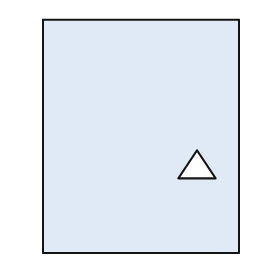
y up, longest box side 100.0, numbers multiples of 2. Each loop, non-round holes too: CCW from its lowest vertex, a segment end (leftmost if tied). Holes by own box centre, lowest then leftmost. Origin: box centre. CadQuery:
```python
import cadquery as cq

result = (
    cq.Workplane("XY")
    .moveTo(-42.0, -50.0)
    .lineTo(42.0, -50.0)
    .lineTo(42.0, 50.0)
    .lineTo(-42.0, 50.0)
    .close()
    .moveTo(16.0, -18.0)
    .lineTo(32.0, -18.0)
    .lineTo(24.0, -6.0)
    .close()
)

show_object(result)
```